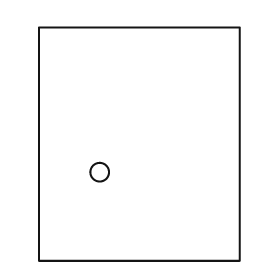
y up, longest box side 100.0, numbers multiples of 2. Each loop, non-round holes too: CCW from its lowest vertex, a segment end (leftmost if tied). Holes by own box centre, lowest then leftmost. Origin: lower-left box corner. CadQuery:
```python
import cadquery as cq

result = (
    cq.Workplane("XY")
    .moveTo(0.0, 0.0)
    .lineTo(86.0, 0.0)
    .lineTo(86.0, 100.0)
    .lineTo(0.0, 100.0)
    .close()
    .moveTo(26.0, 38.0)
    .circle(4.0)
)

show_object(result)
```